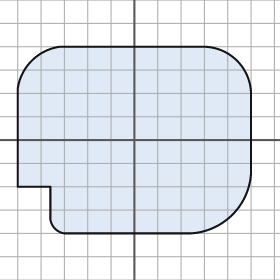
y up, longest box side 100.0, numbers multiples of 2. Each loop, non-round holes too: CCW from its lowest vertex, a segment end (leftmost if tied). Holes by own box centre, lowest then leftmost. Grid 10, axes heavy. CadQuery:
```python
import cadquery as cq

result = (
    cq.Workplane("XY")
    .moveTo(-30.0, -40.0)
    .lineTo(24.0, -40.0)
    .threePointArc((42.0, -32.0), (50.0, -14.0))
    .lineTo(50.0, 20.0)
    .threePointArc((44.0, 34.0), (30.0, 40.0))
    .lineTo(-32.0, 40.0)
    .threePointArc((-44.0, 34.0), (-50.0, 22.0))
    .lineTo(-50.0, -20.0)
    .lineTo(-36.0, -20.0)
    .lineTo(-36.0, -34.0)
    .threePointArc((-34.0, -38.0), (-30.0, -40.0))
    .close()
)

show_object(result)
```